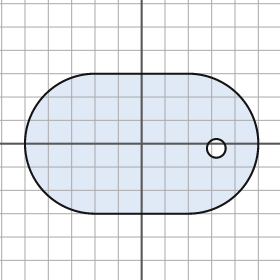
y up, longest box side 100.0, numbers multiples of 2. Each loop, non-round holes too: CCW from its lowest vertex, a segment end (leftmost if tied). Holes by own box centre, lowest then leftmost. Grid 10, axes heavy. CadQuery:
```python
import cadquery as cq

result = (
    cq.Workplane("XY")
    .moveTo(-20.0, -30.0)
    .lineTo(20.0, -30.0)
    .threePointArc((50.0, 0.0), (20.0, 30.0))
    .lineTo(-20.0, 30.0)
    .threePointArc((-50.0, 0.0), (-20.0, -30.0))
    .close()
    .moveTo(32.0, -2.0)
    .circle(4.0)
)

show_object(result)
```